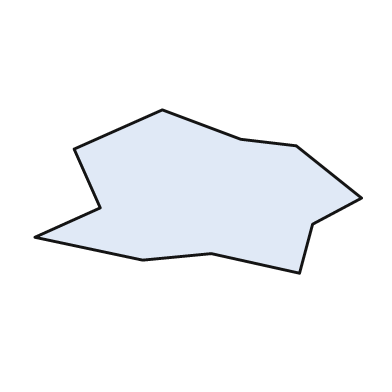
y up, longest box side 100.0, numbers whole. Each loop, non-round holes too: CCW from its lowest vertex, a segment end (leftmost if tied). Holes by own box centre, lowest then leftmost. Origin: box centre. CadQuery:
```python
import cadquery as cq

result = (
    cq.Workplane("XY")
    .moveTo(31.0, -25.0)
    .lineTo(35.0, -10.0)
    .lineTo(50.0, -2.0)
    .lineTo(30.0, 14.0)
    .lineTo(13.0, 16.0)
    .lineTo(-11.0, 25.0)
    .lineTo(-38.0, 13.0)
    .lineTo(-30.0, -5.0)
    .lineTo(-50.0, -14.0)
    .lineTo(-17.0, -21.0)
    .lineTo(4.0, -19.0)
    .close()
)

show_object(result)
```